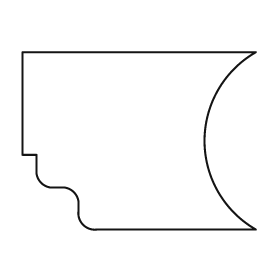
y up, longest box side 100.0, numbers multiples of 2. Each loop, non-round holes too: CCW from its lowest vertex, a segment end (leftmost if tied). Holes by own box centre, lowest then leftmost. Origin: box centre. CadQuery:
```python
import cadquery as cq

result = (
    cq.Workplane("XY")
    .moveTo(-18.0, -38.0)
    .lineTo(50.0, -38.0)
    .threePointArc((28.0, 0.0), (50.0, 38.0))
    .lineTo(-50.0, 38.0)
    .lineTo(-50.0, -6.0)
    .lineTo(-44.0, -6.0)
    .lineTo(-44.0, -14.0)
    .threePointArc((-42.0, -18.0), (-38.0, -20.0))
    .lineTo(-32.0, -20.0)
    .threePointArc((-28.0, -22.0), (-26.0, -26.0))
    .lineTo(-26.0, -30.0)
    .threePointArc((-24.0, -36.0), (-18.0, -38.0))
    .close()
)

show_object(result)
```